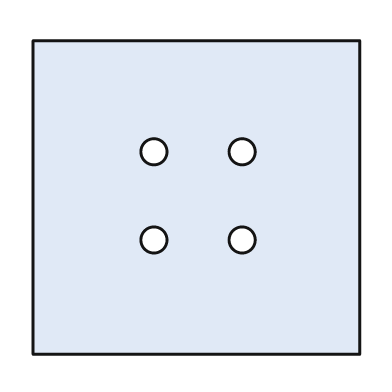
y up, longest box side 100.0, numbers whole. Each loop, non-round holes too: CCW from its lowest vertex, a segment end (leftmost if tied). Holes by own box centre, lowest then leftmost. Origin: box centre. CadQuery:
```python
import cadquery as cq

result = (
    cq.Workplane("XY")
    .moveTo(-50.0, -48.0)
    .lineTo(50.0, -48.0)
    .lineTo(50.0, 48.0)
    .lineTo(-50.0, 48.0)
    .close()
    .moveTo(-13.0, -13.0)
    .circle(4.0)
    .moveTo(14.0, -13.0)
    .circle(4.0)
    .moveTo(-13.0, 14.0)
    .circle(4.0)
    .moveTo(14.0, 14.0)
    .circle(4.0)
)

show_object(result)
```